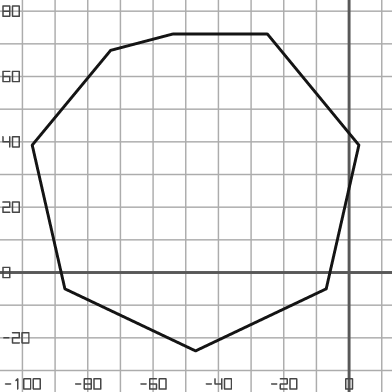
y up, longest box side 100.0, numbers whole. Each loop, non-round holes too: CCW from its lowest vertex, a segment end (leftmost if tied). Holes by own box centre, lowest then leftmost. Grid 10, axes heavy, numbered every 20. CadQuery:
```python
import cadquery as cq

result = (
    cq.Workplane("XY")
    .moveTo(-47.0, -24.0)
    .lineTo(-7.0, -5.0)
    .lineTo(3.0, 39.0)
    .lineTo(-25.0, 73.0)
    .lineTo(-54.0, 73.0)
    .lineTo(-73.0, 68.0)
    .lineTo(-97.0, 39.0)
    .lineTo(-87.0, -5.0)
    .close()
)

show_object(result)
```